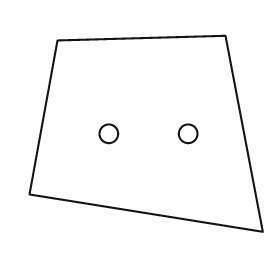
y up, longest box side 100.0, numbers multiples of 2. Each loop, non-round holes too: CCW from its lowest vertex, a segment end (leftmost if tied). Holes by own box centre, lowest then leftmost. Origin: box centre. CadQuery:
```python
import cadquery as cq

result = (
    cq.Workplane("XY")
    .moveTo(50.0, -42.0)
    .lineTo(34.0, 42.0)
    .lineTo(-38.0, 40.0)
    .lineTo(-50.0, -26.0)
    .close()
    .moveTo(-16.0, 0.0)
    .circle(4.0)
    .moveTo(18.0, 0.0)
    .circle(4.0)
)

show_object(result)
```